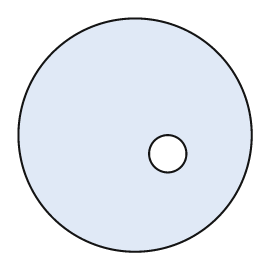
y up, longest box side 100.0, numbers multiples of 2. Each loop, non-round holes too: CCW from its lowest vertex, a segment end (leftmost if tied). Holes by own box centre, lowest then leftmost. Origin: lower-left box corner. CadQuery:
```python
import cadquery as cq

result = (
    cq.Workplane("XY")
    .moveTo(50.0, 50.0)
    .circle(50.0)
    .moveTo(64.0, 42.0)
    .circle(8.0)
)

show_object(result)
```